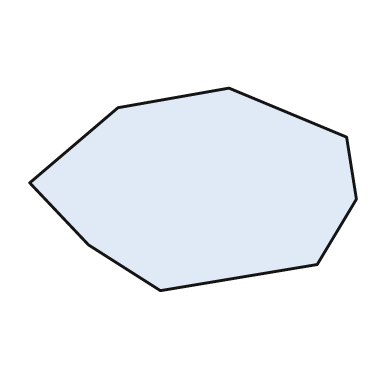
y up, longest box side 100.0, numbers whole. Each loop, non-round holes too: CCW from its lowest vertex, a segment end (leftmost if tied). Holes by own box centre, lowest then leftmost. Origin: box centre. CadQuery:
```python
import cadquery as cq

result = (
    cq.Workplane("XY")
    .moveTo(-10.0, -31.0)
    .lineTo(38.0, -23.0)
    .lineTo(50.0, -3.0)
    .lineTo(47.0, 16.0)
    .lineTo(11.0, 31.0)
    .lineTo(-23.0, 25.0)
    .lineTo(-50.0, 2.0)
    .lineTo(-32.0, -17.0)
    .close()
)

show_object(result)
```